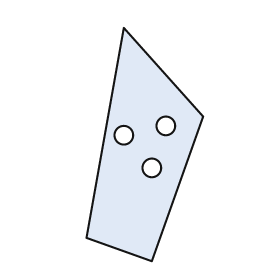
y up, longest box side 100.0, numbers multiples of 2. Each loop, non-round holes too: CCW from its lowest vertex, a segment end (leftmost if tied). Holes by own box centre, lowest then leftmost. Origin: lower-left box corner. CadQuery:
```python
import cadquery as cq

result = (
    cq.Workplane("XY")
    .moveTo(28.0, 0.0)
    .lineTo(50.0, 62.0)
    .lineTo(16.0, 100.0)
    .lineTo(0.0, 10.0)
    .close()
    .moveTo(28.0, 40.0)
    .circle(4.0)
    .moveTo(16.0, 54.0)
    .circle(4.0)
    .moveTo(34.0, 58.0)
    .circle(4.0)
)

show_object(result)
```